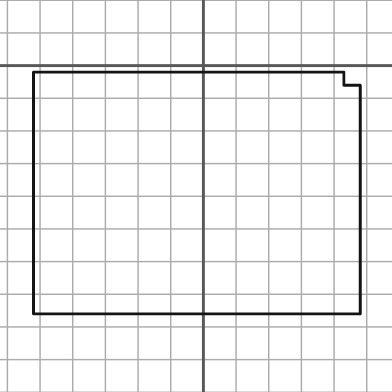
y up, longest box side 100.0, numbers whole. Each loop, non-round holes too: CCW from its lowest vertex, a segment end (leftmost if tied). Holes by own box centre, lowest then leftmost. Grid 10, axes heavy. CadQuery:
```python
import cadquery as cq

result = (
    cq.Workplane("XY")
    .moveTo(-52.0, -76.0)
    .lineTo(48.0, -76.0)
    .lineTo(48.0, -6.0)
    .lineTo(43.0, -6.0)
    .lineTo(43.0, -2.0)
    .lineTo(-52.0, -2.0)
    .close()
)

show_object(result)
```